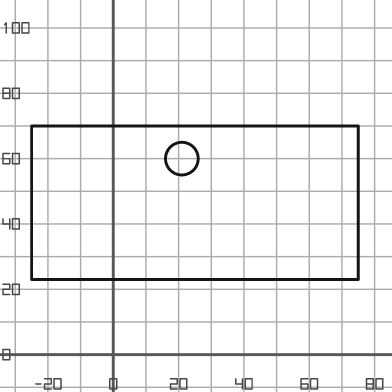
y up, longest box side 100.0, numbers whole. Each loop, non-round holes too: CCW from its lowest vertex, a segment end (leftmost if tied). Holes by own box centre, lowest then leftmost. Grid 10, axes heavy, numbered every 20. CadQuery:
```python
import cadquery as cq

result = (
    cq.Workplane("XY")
    .moveTo(-25.0, 23.0)
    .lineTo(75.0, 23.0)
    .lineTo(75.0, 70.0)
    .lineTo(-25.0, 70.0)
    .close()
    .moveTo(21.0, 60.0)
    .circle(5.0)
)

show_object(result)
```